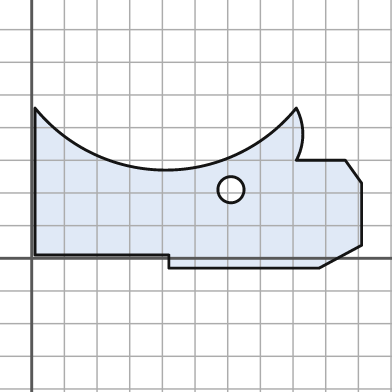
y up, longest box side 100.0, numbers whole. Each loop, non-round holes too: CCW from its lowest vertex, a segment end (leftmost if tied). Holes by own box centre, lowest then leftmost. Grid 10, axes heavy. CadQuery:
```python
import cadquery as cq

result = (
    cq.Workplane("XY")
    .moveTo(42.0, -3.0)
    .lineTo(88.0, -3.0)
    .lineTo(101.0, 4.0)
    .lineTo(101.0, 23.0)
    .lineTo(96.0, 30.0)
    .lineTo(81.0, 30.0)
    .threePointArc((83.0, 38.0), (81.0, 46.0))
    .threePointArc((41.0, 27.0), (1.0, 46.0))
    .lineTo(1.0, 1.0)
    .lineTo(42.0, 1.0)
    .close()
    .moveTo(61.0, 21.0)
    .circle(4.0)
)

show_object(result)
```